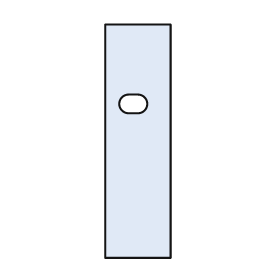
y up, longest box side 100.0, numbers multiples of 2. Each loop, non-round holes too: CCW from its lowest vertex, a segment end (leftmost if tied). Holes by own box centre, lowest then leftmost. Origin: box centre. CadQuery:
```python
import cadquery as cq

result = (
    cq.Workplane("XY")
    .moveTo(-14.0, -50.0)
    .lineTo(14.0, -50.0)
    .lineTo(14.0, 50.0)
    .lineTo(-14.0, 50.0)
    .close()
    .moveTo(-4.0, 12.0)
    .lineTo(0.0, 12.0)
    .threePointArc((4.0, 16.0), (0.0, 20.0))
    .lineTo(-4.0, 20.0)
    .threePointArc((-8.0, 16.0), (-4.0, 12.0))
    .close()
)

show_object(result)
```